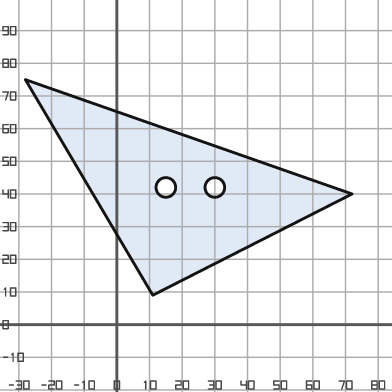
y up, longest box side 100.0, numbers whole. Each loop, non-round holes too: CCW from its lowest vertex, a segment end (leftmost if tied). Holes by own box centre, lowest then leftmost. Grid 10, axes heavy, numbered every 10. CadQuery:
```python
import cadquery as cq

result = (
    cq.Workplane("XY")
    .moveTo(11.0, 9.0)
    .lineTo(72.0, 40.0)
    .lineTo(-28.0, 75.0)
    .close()
    .moveTo(15.0, 42.0)
    .circle(3.0)
    .moveTo(30.0, 42.0)
    .circle(3.0)
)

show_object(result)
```